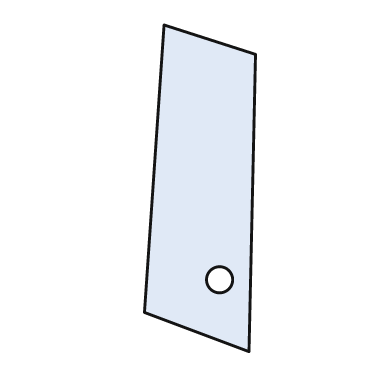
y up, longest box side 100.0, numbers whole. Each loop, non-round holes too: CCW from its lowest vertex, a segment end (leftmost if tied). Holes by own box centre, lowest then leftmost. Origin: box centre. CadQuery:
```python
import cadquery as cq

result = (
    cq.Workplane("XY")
    .moveTo(15.0, -50.0)
    .lineTo(17.0, 41.0)
    .lineTo(-11.0, 50.0)
    .lineTo(-17.0, -38.0)
    .close()
    .moveTo(6.0, -28.0)
    .circle(4.0)
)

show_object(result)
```